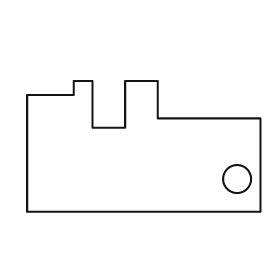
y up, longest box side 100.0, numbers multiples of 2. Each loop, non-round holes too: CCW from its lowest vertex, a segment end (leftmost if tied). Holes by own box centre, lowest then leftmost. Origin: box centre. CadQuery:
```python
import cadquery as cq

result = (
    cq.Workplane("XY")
    .moveTo(-50.0, -28.0)
    .lineTo(50.0, -28.0)
    .lineTo(50.0, 12.0)
    .lineTo(6.0, 12.0)
    .lineTo(6.0, 28.0)
    .lineTo(-8.0, 28.0)
    .lineTo(-8.0, 8.0)
    .lineTo(-22.0, 8.0)
    .lineTo(-22.0, 28.0)
    .lineTo(-30.0, 28.0)
    .lineTo(-30.0, 22.0)
    .lineTo(-50.0, 22.0)
    .close()
    .moveTo(40.0, -14.0)
    .circle(6.0)
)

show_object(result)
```